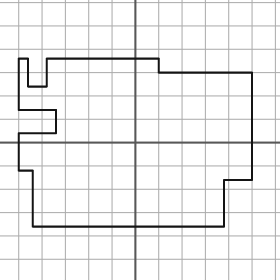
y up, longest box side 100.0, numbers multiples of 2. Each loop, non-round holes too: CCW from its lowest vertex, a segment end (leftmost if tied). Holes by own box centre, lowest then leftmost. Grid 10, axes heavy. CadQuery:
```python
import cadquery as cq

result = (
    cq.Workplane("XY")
    .moveTo(-44.0, -36.0)
    .lineTo(38.0, -36.0)
    .lineTo(38.0, -16.0)
    .lineTo(50.0, -16.0)
    .lineTo(50.0, 30.0)
    .lineTo(10.0, 30.0)
    .lineTo(10.0, 36.0)
    .lineTo(-38.0, 36.0)
    .lineTo(-38.0, 24.0)
    .lineTo(-46.0, 24.0)
    .lineTo(-46.0, 36.0)
    .lineTo(-50.0, 36.0)
    .lineTo(-50.0, 14.0)
    .lineTo(-34.0, 14.0)
    .lineTo(-34.0, 4.0)
    .lineTo(-50.0, 4.0)
    .lineTo(-50.0, -12.0)
    .lineTo(-44.0, -12.0)
    .close()
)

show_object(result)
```